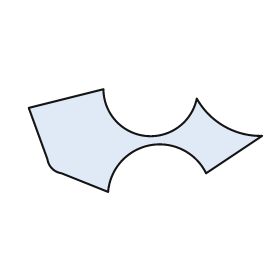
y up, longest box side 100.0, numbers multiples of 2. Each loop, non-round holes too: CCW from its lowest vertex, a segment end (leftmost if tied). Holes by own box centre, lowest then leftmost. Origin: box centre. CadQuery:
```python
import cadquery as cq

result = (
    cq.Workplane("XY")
    .moveTo(-16.0, -22.0)
    .threePointArc((2.0, -2.0), (26.0, -14.0))
    .lineTo(50.0, 2.0)
    .threePointArc((34.0, 6.0), (22.0, 18.0))
    .threePointArc((0.0, 2.0), (-18.0, 22.0))
    .lineTo(-50.0, 14.0)
    .lineTo(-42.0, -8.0)
    .threePointArc((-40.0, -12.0), (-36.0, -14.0))
    .close()
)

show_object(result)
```